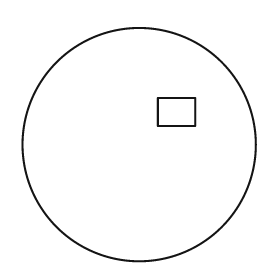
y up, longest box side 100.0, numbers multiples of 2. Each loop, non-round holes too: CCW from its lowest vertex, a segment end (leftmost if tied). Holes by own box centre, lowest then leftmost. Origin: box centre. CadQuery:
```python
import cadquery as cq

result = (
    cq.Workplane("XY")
    .moveTo(0.0, 0.0)
    .circle(50.0)
    .moveTo(8.0, 8.0)
    .lineTo(24.0, 8.0)
    .lineTo(24.0, 20.0)
    .lineTo(8.0, 20.0)
    .close()
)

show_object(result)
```